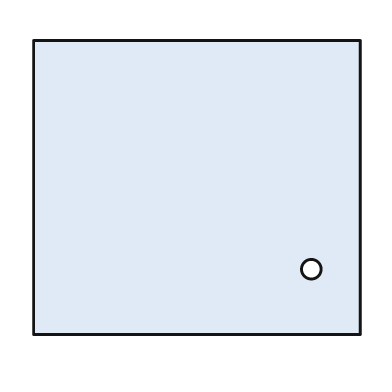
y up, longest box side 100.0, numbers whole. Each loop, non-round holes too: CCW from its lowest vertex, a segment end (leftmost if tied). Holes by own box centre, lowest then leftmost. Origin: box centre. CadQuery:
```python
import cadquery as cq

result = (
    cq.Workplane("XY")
    .moveTo(-50.0, -45.0)
    .lineTo(50.0, -45.0)
    .lineTo(50.0, 45.0)
    .lineTo(-50.0, 45.0)
    .close()
    .moveTo(35.0, -25.0)
    .circle(3.0)
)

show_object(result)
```